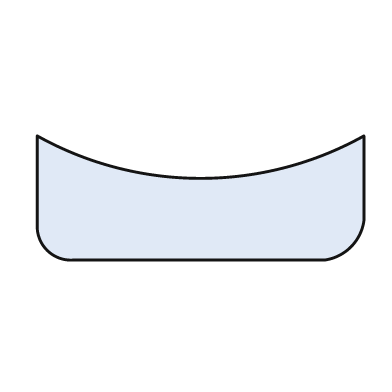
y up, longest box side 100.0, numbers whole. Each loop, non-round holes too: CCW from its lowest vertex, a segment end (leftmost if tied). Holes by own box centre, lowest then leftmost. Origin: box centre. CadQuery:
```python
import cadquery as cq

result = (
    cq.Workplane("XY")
    .moveTo(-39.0, -19.0)
    .lineTo(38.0, -19.0)
    .threePointArc((46.0, -15.0), (50.0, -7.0))
    .lineTo(50.0, 19.0)
    .threePointArc((0.0, 6.0), (-50.0, 19.0))
    .lineTo(-50.0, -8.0)
    .threePointArc((-47.0, -16.0), (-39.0, -19.0))
    .close()
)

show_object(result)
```